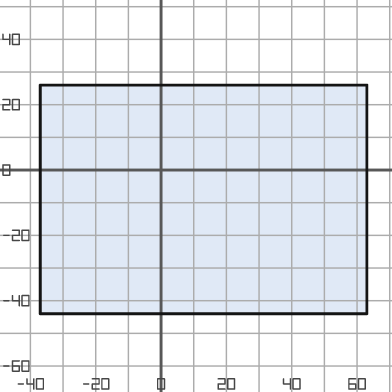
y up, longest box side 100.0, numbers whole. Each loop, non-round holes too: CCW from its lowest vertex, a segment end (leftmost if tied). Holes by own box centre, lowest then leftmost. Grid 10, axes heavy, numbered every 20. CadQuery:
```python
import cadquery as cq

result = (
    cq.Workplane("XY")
    .moveTo(-37.0, -44.0)
    .lineTo(63.0, -44.0)
    .lineTo(63.0, 26.0)
    .lineTo(-37.0, 26.0)
    .close()
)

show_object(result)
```